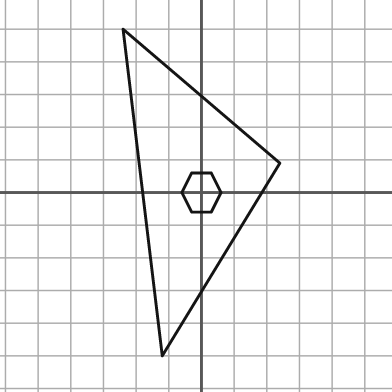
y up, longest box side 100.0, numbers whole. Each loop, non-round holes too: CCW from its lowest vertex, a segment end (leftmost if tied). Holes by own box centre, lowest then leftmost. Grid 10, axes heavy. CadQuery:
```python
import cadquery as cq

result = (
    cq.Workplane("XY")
    .moveTo(-12.0, -50.0)
    .lineTo(24.0, 9.0)
    .lineTo(-24.0, 50.0)
    .close()
    .moveTo(-3.0, -6.0)
    .lineTo(3.0, -6.0)
    .lineTo(6.0, 0.0)
    .lineTo(3.0, 6.0)
    .lineTo(-3.0, 6.0)
    .lineTo(-6.0, 0.0)
    .close()
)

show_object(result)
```